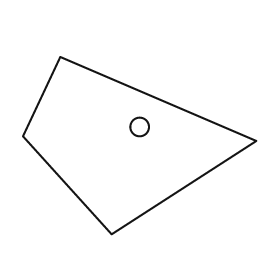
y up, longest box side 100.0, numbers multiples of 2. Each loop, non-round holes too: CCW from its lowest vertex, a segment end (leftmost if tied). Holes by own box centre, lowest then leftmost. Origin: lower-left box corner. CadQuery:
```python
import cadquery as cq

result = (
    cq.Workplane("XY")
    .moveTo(38.0, 0.0)
    .lineTo(100.0, 40.0)
    .lineTo(16.0, 76.0)
    .lineTo(0.0, 42.0)
    .close()
    .moveTo(50.0, 46.0)
    .circle(4.0)
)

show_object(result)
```